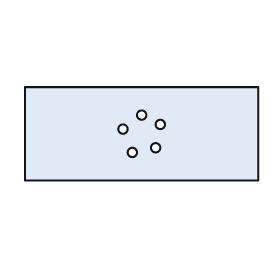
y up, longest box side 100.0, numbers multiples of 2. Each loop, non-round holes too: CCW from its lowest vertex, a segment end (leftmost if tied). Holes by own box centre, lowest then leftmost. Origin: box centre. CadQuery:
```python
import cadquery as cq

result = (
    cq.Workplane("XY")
    .moveTo(-50.0, -20.0)
    .lineTo(50.0, -20.0)
    .lineTo(50.0, 20.0)
    .lineTo(-50.0, 20.0)
    .close()
    .moveTo(-4.0, -8.0)
    .circle(2.0)
    .moveTo(6.0, -6.0)
    .circle(2.0)
    .moveTo(-8.0, 2.0)
    .circle(2.0)
    .moveTo(8.0, 4.0)
    .circle(2.0)
    .moveTo(0.0, 8.0)
    .circle(2.0)
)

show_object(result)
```